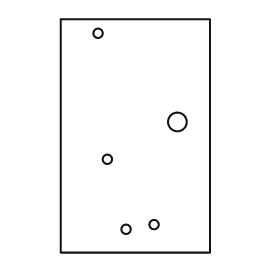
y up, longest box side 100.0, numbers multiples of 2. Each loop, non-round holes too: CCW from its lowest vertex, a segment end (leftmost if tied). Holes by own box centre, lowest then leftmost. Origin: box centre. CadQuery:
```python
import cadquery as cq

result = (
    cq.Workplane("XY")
    .moveTo(-32.0, -50.0)
    .lineTo(32.0, -50.0)
    .lineTo(32.0, 50.0)
    .lineTo(-32.0, 50.0)
    .close()
    .moveTo(-4.0, -40.0)
    .circle(2.0)
    .moveTo(8.0, -38.0)
    .circle(2.0)
    .moveTo(-12.0, -10.0)
    .circle(2.0)
    .moveTo(18.0, 6.0)
    .circle(4.0)
    .moveTo(-16.0, 44.0)
    .circle(2.0)
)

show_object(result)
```